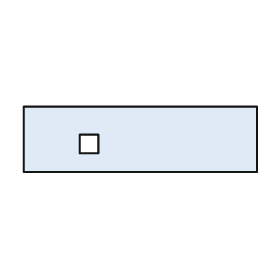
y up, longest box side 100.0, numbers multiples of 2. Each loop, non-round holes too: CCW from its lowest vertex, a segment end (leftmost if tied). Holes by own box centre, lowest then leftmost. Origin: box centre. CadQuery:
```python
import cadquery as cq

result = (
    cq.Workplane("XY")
    .moveTo(-50.0, -14.0)
    .lineTo(50.0, -14.0)
    .lineTo(50.0, 14.0)
    .lineTo(-50.0, 14.0)
    .close()
    .moveTo(-26.0, -6.0)
    .lineTo(-18.0, -6.0)
    .lineTo(-18.0, 2.0)
    .lineTo(-26.0, 2.0)
    .close()
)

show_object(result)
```